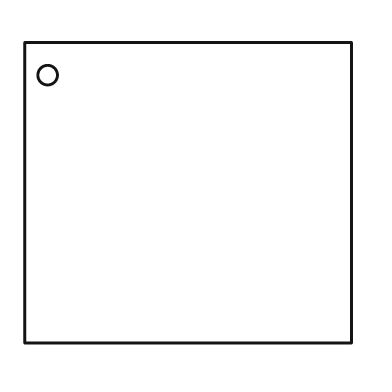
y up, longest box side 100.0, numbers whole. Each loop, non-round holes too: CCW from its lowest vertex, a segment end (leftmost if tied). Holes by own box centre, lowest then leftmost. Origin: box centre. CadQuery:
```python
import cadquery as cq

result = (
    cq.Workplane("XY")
    .moveTo(-50.0, -46.0)
    .lineTo(50.0, -46.0)
    .lineTo(50.0, 46.0)
    .lineTo(-50.0, 46.0)
    .close()
    .moveTo(-43.0, 36.0)
    .circle(3.0)
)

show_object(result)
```